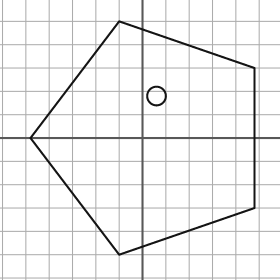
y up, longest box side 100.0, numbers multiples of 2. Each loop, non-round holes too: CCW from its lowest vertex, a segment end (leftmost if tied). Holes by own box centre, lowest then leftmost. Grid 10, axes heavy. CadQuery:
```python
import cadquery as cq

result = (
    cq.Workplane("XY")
    .moveTo(-10.0, -50.0)
    .lineTo(48.0, -30.0)
    .lineTo(48.0, 30.0)
    .lineTo(-10.0, 50.0)
    .lineTo(-48.0, 0.0)
    .close()
    .moveTo(6.0, 18.0)
    .circle(4.0)
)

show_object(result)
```